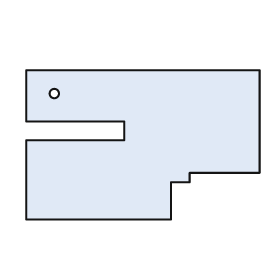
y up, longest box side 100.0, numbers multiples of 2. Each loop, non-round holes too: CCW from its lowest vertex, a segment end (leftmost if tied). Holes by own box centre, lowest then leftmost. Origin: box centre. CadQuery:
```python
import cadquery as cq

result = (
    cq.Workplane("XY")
    .moveTo(-50.0, -32.0)
    .lineTo(12.0, -32.0)
    .lineTo(12.0, -16.0)
    .lineTo(20.0, -16.0)
    .lineTo(20.0, -12.0)
    .lineTo(50.0, -12.0)
    .lineTo(50.0, 32.0)
    .lineTo(-50.0, 32.0)
    .lineTo(-50.0, 10.0)
    .lineTo(-8.0, 10.0)
    .lineTo(-8.0, 2.0)
    .lineTo(-50.0, 2.0)
    .close()
    .moveTo(-38.0, 22.0)
    .circle(2.0)
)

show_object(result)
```